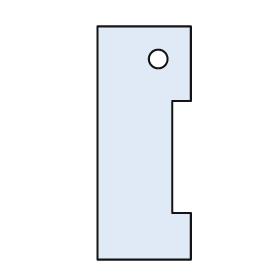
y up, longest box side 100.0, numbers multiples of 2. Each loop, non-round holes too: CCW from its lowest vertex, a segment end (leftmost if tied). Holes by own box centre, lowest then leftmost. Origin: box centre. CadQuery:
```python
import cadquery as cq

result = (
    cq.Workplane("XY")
    .moveTo(-20.0, -50.0)
    .lineTo(20.0, -50.0)
    .lineTo(20.0, -30.0)
    .lineTo(12.0, -30.0)
    .lineTo(12.0, 18.0)
    .lineTo(20.0, 18.0)
    .lineTo(20.0, 50.0)
    .lineTo(-20.0, 50.0)
    .close()
    .moveTo(6.0, 36.0)
    .circle(4.0)
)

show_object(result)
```